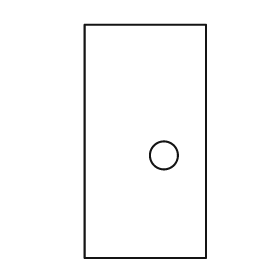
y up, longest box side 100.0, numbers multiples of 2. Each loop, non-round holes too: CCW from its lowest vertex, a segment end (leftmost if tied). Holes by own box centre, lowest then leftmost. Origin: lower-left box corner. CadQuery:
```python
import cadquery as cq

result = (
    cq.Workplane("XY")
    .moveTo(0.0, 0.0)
    .lineTo(52.0, 0.0)
    .lineTo(52.0, 100.0)
    .lineTo(0.0, 100.0)
    .close()
    .moveTo(34.0, 44.0)
    .circle(6.0)
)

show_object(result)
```